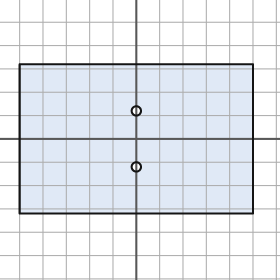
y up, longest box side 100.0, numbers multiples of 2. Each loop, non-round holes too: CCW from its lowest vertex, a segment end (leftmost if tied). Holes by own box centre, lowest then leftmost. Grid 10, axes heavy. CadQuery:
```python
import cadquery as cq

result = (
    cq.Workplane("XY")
    .moveTo(-50.0, -32.0)
    .lineTo(50.0, -32.0)
    .lineTo(50.0, 32.0)
    .lineTo(-50.0, 32.0)
    .close()
    .moveTo(0.0, -12.0)
    .circle(2.0)
    .moveTo(0.0, 12.0)
    .circle(2.0)
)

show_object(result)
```